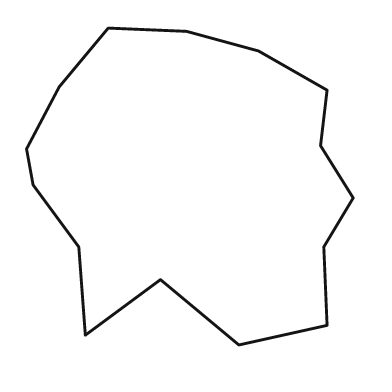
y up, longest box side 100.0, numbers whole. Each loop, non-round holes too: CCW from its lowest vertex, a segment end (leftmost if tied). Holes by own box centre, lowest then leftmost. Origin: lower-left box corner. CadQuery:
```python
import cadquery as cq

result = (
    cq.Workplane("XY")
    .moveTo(65.0, 0.0)
    .lineTo(92.0, 6.0)
    .lineTo(91.0, 30.0)
    .lineTo(100.0, 45.0)
    .lineTo(90.0, 61.0)
    .lineTo(92.0, 78.0)
    .lineTo(71.0, 90.0)
    .lineTo(49.0, 96.0)
    .lineTo(25.0, 97.0)
    .lineTo(10.0, 79.0)
    .lineTo(0.0, 60.0)
    .lineTo(2.0, 49.0)
    .lineTo(16.0, 30.0)
    .lineTo(18.0, 3.0)
    .lineTo(41.0, 20.0)
    .close()
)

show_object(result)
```